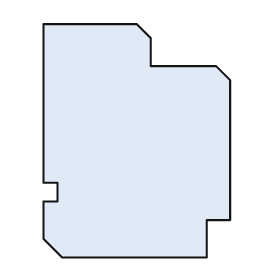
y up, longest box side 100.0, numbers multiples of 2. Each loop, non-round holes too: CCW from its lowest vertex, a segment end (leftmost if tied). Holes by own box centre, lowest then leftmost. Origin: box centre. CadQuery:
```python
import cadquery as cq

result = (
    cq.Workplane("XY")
    .moveTo(-32.0, -50.0)
    .lineTo(30.0, -50.0)
    .lineTo(30.0, -34.0)
    .lineTo(40.0, -34.0)
    .lineTo(40.0, 26.0)
    .lineTo(34.0, 32.0)
    .lineTo(6.0, 32.0)
    .lineTo(6.0, 44.0)
    .lineTo(0.0, 50.0)
    .lineTo(-40.0, 50.0)
    .lineTo(-40.0, -18.0)
    .lineTo(-34.0, -18.0)
    .lineTo(-34.0, -26.0)
    .lineTo(-40.0, -26.0)
    .lineTo(-40.0, -42.0)
    .close()
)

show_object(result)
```